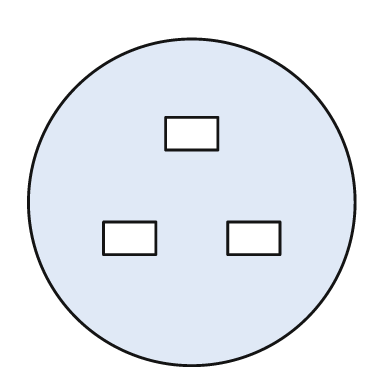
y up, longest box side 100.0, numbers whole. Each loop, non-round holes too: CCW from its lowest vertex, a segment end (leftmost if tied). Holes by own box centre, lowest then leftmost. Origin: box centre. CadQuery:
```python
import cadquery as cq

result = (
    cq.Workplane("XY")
    .moveTo(0.0, 0.0)
    .circle(50.0)
    .moveTo(-27.0, -16.0)
    .lineTo(-11.0, -16.0)
    .lineTo(-11.0, -6.0)
    .lineTo(-27.0, -6.0)
    .close()
    .moveTo(11.0, -16.0)
    .lineTo(27.0, -16.0)
    .lineTo(27.0, -6.0)
    .lineTo(11.0, -6.0)
    .close()
    .moveTo(-8.0, 16.0)
    .lineTo(8.0, 16.0)
    .lineTo(8.0, 26.0)
    .lineTo(-8.0, 26.0)
    .close()
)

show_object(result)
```